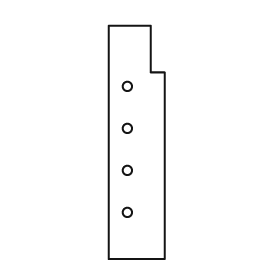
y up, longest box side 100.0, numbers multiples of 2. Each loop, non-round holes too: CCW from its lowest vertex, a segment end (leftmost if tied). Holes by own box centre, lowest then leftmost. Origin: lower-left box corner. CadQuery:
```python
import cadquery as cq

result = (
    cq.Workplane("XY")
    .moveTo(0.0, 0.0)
    .lineTo(24.0, 0.0)
    .lineTo(24.0, 80.0)
    .lineTo(18.0, 80.0)
    .lineTo(18.0, 100.0)
    .lineTo(0.0, 100.0)
    .close()
    .moveTo(8.0, 20.0)
    .circle(2.0)
    .moveTo(8.0, 38.0)
    .circle(2.0)
    .moveTo(8.0, 56.0)
    .circle(2.0)
    .moveTo(8.0, 74.0)
    .circle(2.0)
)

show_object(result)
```